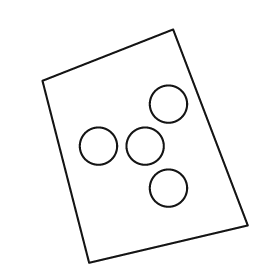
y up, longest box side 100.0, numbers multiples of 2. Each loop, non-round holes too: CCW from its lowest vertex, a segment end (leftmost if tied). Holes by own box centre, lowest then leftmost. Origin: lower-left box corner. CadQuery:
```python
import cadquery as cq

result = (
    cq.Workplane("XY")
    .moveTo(20.0, 0.0)
    .lineTo(88.0, 16.0)
    .lineTo(56.0, 100.0)
    .lineTo(0.0, 78.0)
    .close()
    .moveTo(54.0, 32.0)
    .circle(8.0)
    .moveTo(24.0, 50.0)
    .circle(8.0)
    .moveTo(44.0, 50.0)
    .circle(8.0)
    .moveTo(54.0, 68.0)
    .circle(8.0)
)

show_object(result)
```